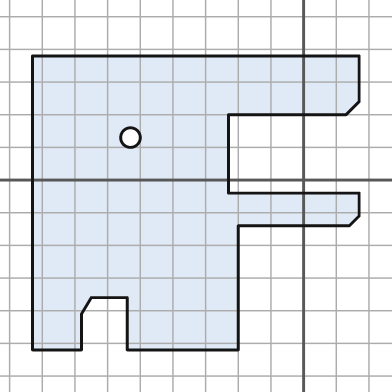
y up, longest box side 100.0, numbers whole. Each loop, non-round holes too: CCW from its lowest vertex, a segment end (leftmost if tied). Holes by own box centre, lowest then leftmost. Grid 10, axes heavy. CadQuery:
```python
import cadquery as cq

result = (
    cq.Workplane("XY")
    .moveTo(-83.0, -52.0)
    .lineTo(-68.0, -52.0)
    .lineTo(-68.0, -41.0)
    .lineTo(-65.0, -36.0)
    .lineTo(-54.0, -36.0)
    .lineTo(-54.0, -52.0)
    .lineTo(-20.0, -52.0)
    .lineTo(-20.0, -14.0)
    .lineTo(14.0, -14.0)
    .lineTo(17.0, -11.0)
    .lineTo(17.0, -4.0)
    .lineTo(-23.0, -4.0)
    .lineTo(-23.0, 20.0)
    .lineTo(13.0, 20.0)
    .lineTo(17.0, 24.0)
    .lineTo(17.0, 38.0)
    .lineTo(-83.0, 38.0)
    .close()
    .moveTo(-53.0, 13.0)
    .circle(3.0)
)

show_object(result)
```